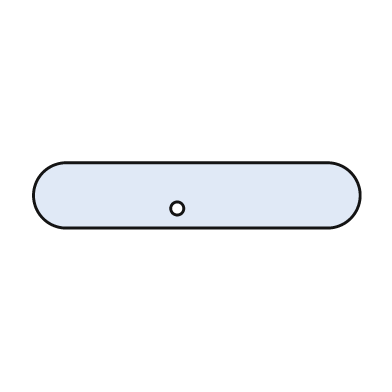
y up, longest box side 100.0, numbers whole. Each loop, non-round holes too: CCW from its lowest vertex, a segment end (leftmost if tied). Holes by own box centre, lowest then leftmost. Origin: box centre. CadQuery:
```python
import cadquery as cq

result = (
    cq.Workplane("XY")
    .moveTo(-40.0, -10.0)
    .lineTo(40.0, -10.0)
    .threePointArc((50.0, 0.0), (40.0, 10.0))
    .lineTo(-40.0, 10.0)
    .threePointArc((-50.0, 0.0), (-40.0, -10.0))
    .close()
    .moveTo(-6.0, -4.0)
    .circle(2.0)
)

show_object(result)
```